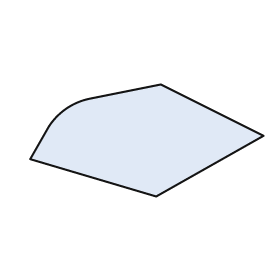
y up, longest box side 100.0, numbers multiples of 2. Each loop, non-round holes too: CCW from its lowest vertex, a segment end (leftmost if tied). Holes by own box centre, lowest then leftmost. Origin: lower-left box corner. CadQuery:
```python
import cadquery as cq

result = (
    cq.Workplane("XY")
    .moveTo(54.0, 0.0)
    .lineTo(100.0, 26.0)
    .lineTo(56.0, 48.0)
    .lineTo(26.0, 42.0)
    .threePointArc((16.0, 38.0), (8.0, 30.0))
    .lineTo(0.0, 16.0)
    .close()
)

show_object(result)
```